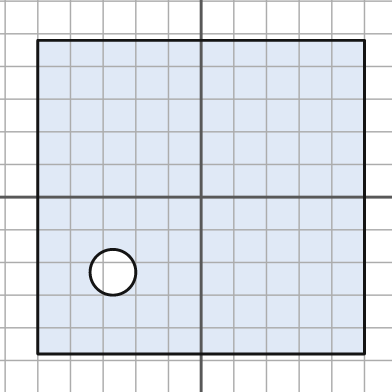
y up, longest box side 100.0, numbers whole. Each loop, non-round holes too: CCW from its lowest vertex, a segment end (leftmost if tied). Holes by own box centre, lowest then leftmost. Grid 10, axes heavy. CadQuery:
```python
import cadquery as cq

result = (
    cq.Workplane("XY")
    .moveTo(-50.0, -48.0)
    .lineTo(50.0, -48.0)
    .lineTo(50.0, 48.0)
    .lineTo(-50.0, 48.0)
    .close()
    .moveTo(-27.0, -23.0)
    .circle(7.0)
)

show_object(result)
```